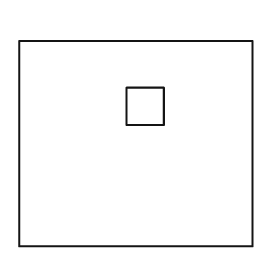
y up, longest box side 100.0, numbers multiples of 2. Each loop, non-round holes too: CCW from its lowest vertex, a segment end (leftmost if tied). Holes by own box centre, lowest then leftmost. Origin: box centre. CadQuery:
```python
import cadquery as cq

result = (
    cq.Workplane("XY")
    .moveTo(-50.0, -44.0)
    .lineTo(50.0, -44.0)
    .lineTo(50.0, 44.0)
    .lineTo(-50.0, 44.0)
    .close()
    .moveTo(-4.0, 8.0)
    .lineTo(12.0, 8.0)
    .lineTo(12.0, 24.0)
    .lineTo(-4.0, 24.0)
    .close()
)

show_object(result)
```